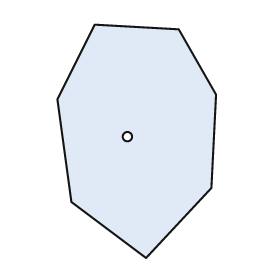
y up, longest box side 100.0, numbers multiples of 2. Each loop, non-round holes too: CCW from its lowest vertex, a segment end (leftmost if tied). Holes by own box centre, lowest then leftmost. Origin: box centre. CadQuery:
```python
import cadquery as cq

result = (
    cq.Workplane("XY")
    .moveTo(4.0, -50.0)
    .lineTo(32.0, -20.0)
    .lineTo(34.0, 20.0)
    .lineTo(18.0, 48.0)
    .lineTo(-18.0, 50.0)
    .lineTo(-34.0, 18.0)
    .lineTo(-28.0, -26.0)
    .close()
    .moveTo(-4.0, 2.0)
    .circle(2.0)
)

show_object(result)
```